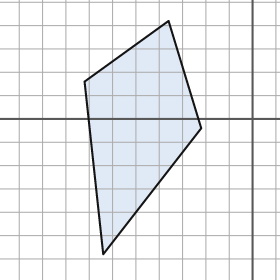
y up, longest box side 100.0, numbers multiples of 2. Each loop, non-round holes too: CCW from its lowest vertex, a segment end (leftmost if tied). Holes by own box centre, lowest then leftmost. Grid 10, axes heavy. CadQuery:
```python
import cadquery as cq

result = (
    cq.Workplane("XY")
    .moveTo(-64.0, -58.0)
    .lineTo(-22.0, -4.0)
    .lineTo(-36.0, 42.0)
    .lineTo(-72.0, 16.0)
    .close()
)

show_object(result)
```